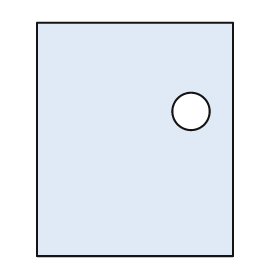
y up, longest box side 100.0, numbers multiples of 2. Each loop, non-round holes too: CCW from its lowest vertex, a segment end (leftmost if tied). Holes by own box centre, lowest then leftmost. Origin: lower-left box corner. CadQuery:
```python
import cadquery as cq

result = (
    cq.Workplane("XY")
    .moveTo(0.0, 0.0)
    .lineTo(84.0, 0.0)
    .lineTo(84.0, 100.0)
    .lineTo(0.0, 100.0)
    .close()
    .moveTo(66.0, 62.0)
    .circle(8.0)
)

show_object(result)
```